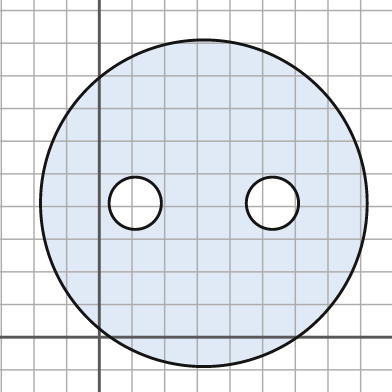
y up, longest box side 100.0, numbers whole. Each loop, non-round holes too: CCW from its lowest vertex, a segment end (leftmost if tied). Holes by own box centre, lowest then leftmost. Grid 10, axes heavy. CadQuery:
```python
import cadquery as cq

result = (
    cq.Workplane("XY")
    .moveTo(32.0, 41.0)
    .circle(50.0)
    .moveTo(11.0, 41.0)
    .circle(8.0)
    .moveTo(53.0, 41.0)
    .circle(8.0)
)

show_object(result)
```